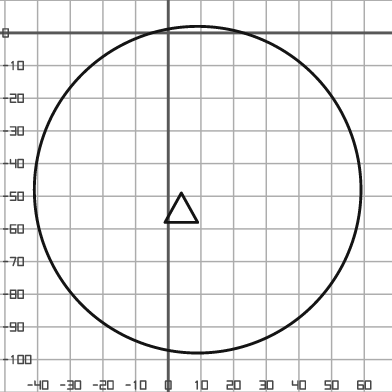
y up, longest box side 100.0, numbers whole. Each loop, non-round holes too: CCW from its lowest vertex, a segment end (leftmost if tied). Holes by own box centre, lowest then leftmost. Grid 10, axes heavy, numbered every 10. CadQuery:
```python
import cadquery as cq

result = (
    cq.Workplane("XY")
    .moveTo(9.0, -48.0)
    .circle(50.0)
    .moveTo(-1.0, -58.0)
    .lineTo(9.0, -58.0)
    .lineTo(4.0, -49.0)
    .close()
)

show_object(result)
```